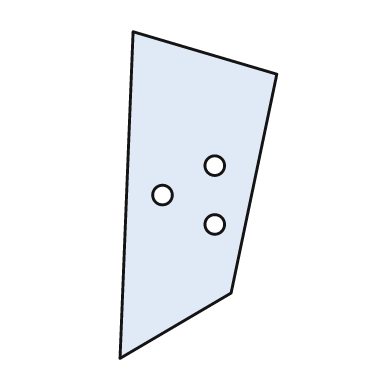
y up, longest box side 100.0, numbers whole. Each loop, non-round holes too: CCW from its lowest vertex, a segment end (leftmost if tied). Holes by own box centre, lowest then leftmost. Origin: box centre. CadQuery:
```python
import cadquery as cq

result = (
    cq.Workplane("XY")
    .moveTo(-24.0, -50.0)
    .lineTo(10.0, -30.0)
    .lineTo(24.0, 37.0)
    .lineTo(-20.0, 50.0)
    .close()
    .moveTo(5.0, -9.0)
    .circle(3.0)
    .moveTo(-11.0, 0.0)
    .circle(3.0)
    .moveTo(5.0, 9.0)
    .circle(3.0)
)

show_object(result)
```